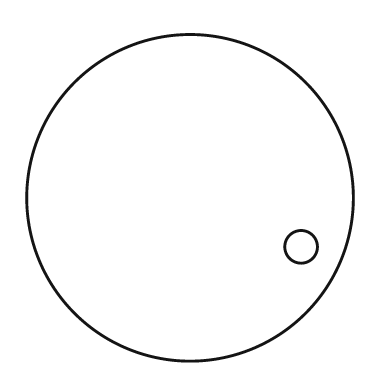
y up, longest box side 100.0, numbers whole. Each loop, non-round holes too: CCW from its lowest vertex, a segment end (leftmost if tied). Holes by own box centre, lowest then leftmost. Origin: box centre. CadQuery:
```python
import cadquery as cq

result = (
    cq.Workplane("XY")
    .moveTo(0.0, 0.0)
    .circle(50.0)
    .moveTo(34.0, -15.0)
    .circle(5.0)
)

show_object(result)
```